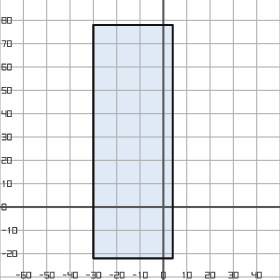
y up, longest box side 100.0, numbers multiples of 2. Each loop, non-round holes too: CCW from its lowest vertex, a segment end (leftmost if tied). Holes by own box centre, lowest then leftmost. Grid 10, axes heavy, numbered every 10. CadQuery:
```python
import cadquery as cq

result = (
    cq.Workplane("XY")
    .moveTo(-30.0, -22.0)
    .lineTo(4.0, -22.0)
    .lineTo(4.0, 78.0)
    .lineTo(-30.0, 78.0)
    .close()
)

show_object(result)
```